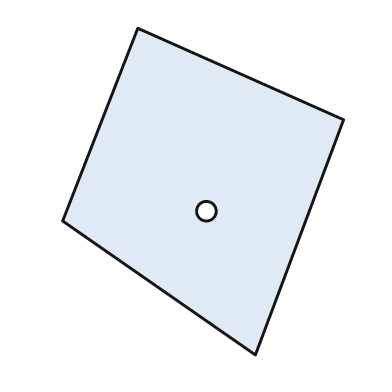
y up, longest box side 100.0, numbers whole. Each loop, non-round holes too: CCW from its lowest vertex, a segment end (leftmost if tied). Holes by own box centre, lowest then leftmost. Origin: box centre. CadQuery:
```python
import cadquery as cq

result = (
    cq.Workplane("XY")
    .moveTo(16.0, -50.0)
    .lineTo(43.0, 22.0)
    .lineTo(-20.0, 50.0)
    .lineTo(-43.0, -9.0)
    .close()
    .moveTo(1.0, -6.0)
    .circle(3.0)
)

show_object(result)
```